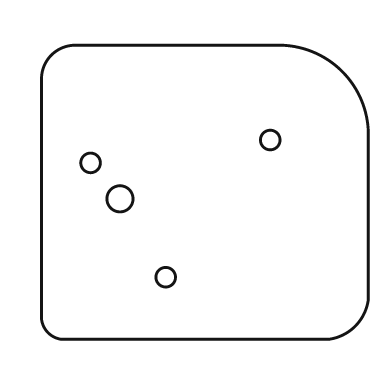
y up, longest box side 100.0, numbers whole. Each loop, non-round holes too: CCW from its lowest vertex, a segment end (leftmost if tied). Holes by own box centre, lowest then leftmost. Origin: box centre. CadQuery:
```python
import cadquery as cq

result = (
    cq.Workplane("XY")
    .moveTo(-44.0, -45.0)
    .lineTo(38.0, -45.0)
    .threePointArc((46.0, -41.0), (50.0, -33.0))
    .lineTo(50.0, 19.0)
    .threePointArc((42.0, 37.0), (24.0, 45.0))
    .lineTo(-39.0, 45.0)
    .threePointArc((-47.0, 42.0), (-50.0, 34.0))
    .lineTo(-50.0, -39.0)
    .threePointArc((-48.0, -43.0), (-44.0, -45.0))
    .close()
    .moveTo(-12.0, -26.0)
    .circle(3.0)
    .moveTo(-26.0, -2.0)
    .circle(4.0)
    .moveTo(-35.0, 9.0)
    .circle(3.0)
    .moveTo(20.0, 16.0)
    .circle(3.0)
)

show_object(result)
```